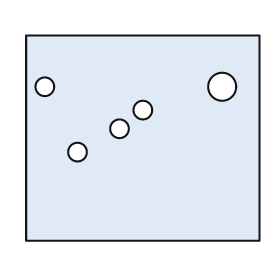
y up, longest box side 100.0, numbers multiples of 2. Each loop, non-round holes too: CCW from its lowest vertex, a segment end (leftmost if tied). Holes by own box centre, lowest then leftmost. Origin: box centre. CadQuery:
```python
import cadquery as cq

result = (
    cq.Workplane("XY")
    .moveTo(-50.0, -44.0)
    .lineTo(50.0, -44.0)
    .lineTo(50.0, 44.0)
    .lineTo(-50.0, 44.0)
    .close()
    .moveTo(-28.0, -6.0)
    .circle(4.0)
    .moveTo(-10.0, 4.0)
    .circle(4.0)
    .moveTo(0.0, 12.0)
    .circle(4.0)
    .moveTo(-42.0, 22.0)
    .circle(4.0)
    .moveTo(34.0, 22.0)
    .circle(6.0)
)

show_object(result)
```